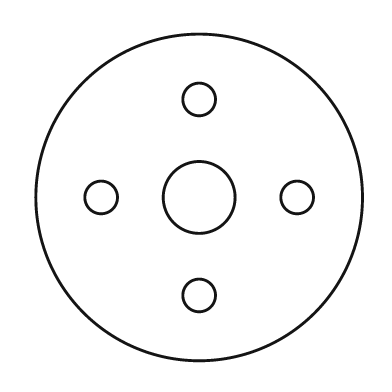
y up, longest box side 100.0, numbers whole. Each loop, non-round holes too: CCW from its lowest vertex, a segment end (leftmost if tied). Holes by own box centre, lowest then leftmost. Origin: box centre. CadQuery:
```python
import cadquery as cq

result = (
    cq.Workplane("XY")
    .moveTo(0.0, 0.0)
    .circle(50.0)
    .moveTo(0.0, -30.0)
    .circle(5.0)
    .moveTo(-30.0, 0.0)
    .circle(5.0)
    .moveTo(0.0, 0.0)
    .circle(11.0)
    .moveTo(30.0, 0.0)
    .circle(5.0)
    .moveTo(0.0, 30.0)
    .circle(5.0)
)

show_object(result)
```